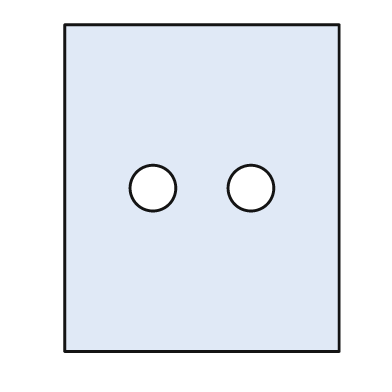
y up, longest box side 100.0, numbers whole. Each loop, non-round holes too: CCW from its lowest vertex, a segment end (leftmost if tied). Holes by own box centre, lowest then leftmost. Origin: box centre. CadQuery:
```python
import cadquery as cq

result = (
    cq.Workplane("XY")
    .moveTo(-42.0, -50.0)
    .lineTo(42.0, -50.0)
    .lineTo(42.0, 50.0)
    .lineTo(-42.0, 50.0)
    .close()
    .moveTo(-15.0, 0.0)
    .circle(7.0)
    .moveTo(15.0, 0.0)
    .circle(7.0)
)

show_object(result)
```